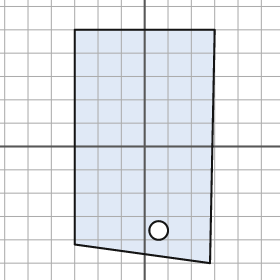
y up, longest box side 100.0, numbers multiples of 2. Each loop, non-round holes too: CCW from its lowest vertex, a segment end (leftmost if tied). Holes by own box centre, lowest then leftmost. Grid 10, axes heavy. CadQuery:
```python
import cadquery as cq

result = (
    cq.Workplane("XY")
    .moveTo(28.0, -50.0)
    .lineTo(30.0, 50.0)
    .lineTo(-30.0, 50.0)
    .lineTo(-30.0, -42.0)
    .close()
    .moveTo(6.0, -36.0)
    .circle(4.0)
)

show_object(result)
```